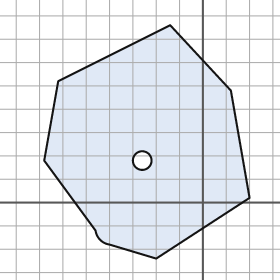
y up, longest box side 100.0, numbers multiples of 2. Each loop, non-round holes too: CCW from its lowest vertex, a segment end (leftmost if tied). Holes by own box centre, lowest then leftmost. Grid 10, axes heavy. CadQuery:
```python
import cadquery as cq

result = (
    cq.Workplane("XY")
    .moveTo(-20.0, -24.0)
    .lineTo(20.0, 2.0)
    .lineTo(12.0, 48.0)
    .lineTo(-14.0, 76.0)
    .lineTo(-62.0, 52.0)
    .lineTo(-68.0, 18.0)
    .lineTo(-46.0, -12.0)
    .threePointArc((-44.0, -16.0), (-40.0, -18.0))
    .close()
    .moveTo(-26.0, 18.0)
    .circle(4.0)
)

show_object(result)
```